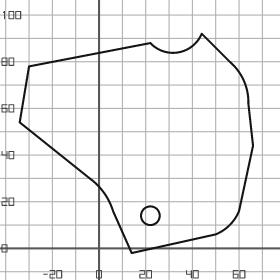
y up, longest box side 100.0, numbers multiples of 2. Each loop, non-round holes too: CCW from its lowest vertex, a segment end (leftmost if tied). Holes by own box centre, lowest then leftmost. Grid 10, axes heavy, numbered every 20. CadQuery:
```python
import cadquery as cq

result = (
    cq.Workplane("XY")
    .moveTo(14.0, -2.0)
    .lineTo(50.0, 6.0)
    .threePointArc((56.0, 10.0), (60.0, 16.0))
    .lineTo(66.0, 44.0)
    .lineTo(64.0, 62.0)
    .threePointArc((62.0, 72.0), (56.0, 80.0))
    .lineTo(44.0, 92.0)
    .threePointArc((34.0, 84.0), (22.0, 88.0))
    .lineTo(-30.0, 78.0)
    .lineTo(-34.0, 54.0)
    .lineTo(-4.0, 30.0)
    .threePointArc((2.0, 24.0), (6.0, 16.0))
    .close()
    .moveTo(22.0, 14.0)
    .circle(4.0)
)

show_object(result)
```